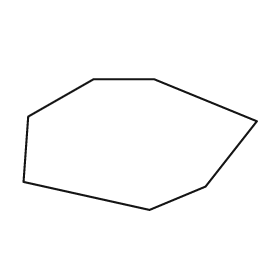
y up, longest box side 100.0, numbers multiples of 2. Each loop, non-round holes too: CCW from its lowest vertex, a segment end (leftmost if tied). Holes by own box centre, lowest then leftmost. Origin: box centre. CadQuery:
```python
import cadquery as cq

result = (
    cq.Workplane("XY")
    .moveTo(4.0, -28.0)
    .lineTo(28.0, -18.0)
    .lineTo(50.0, 10.0)
    .lineTo(6.0, 28.0)
    .lineTo(-20.0, 28.0)
    .lineTo(-48.0, 12.0)
    .lineTo(-50.0, -16.0)
    .close()
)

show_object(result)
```